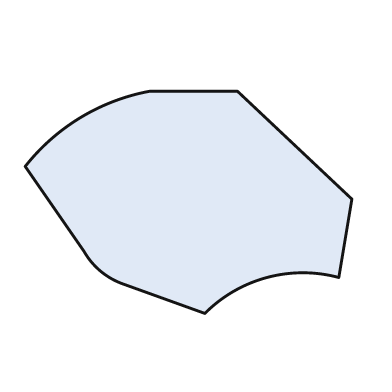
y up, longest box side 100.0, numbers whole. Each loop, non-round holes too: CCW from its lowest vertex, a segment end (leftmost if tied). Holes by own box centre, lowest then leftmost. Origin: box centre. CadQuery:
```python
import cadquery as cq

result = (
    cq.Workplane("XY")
    .moveTo(5.0, -34.0)
    .threePointArc((24.0, -23.0), (46.0, -23.0))
    .lineTo(50.0, 1.0)
    .lineTo(15.0, 34.0)
    .lineTo(-12.0, 34.0)
    .threePointArc((-33.0, 26.0), (-50.0, 11.0))
    .lineTo(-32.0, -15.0)
    .threePointArc((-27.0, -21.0), (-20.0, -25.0))
    .close()
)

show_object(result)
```